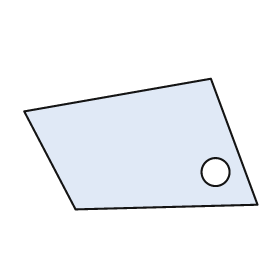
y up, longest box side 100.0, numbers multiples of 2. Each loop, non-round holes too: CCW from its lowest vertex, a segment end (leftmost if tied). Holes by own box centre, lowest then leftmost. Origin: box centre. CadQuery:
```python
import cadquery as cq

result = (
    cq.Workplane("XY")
    .moveTo(-28.0, -28.0)
    .lineTo(50.0, -26.0)
    .lineTo(30.0, 28.0)
    .lineTo(-50.0, 14.0)
    .close()
    .moveTo(32.0, -12.0)
    .circle(6.0)
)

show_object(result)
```